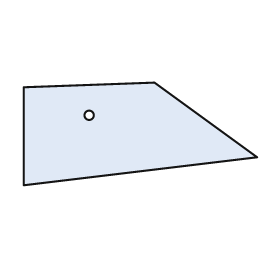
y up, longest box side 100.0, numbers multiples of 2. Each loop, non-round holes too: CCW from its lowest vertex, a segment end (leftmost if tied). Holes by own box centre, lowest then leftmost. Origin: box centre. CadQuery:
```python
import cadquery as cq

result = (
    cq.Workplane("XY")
    .moveTo(-50.0, -22.0)
    .lineTo(50.0, -10.0)
    .lineTo(6.0, 22.0)
    .lineTo(-50.0, 20.0)
    .close()
    .moveTo(-22.0, 8.0)
    .circle(2.0)
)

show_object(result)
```